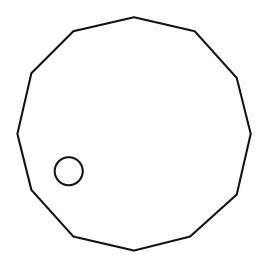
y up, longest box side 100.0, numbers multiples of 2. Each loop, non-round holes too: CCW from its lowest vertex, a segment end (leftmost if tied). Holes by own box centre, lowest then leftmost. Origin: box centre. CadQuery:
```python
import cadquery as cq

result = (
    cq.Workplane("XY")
    .moveTo(0.0, -50.0)
    .lineTo(24.0, -44.0)
    .lineTo(44.0, -26.0)
    .lineTo(50.0, 0.0)
    .lineTo(44.0, 24.0)
    .lineTo(26.0, 44.0)
    .lineTo(0.0, 50.0)
    .lineTo(-26.0, 44.0)
    .lineTo(-44.0, 26.0)
    .lineTo(-50.0, 0.0)
    .lineTo(-44.0, -24.0)
    .lineTo(-26.0, -44.0)
    .close()
    .moveTo(-28.0, -16.0)
    .circle(6.0)
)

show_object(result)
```